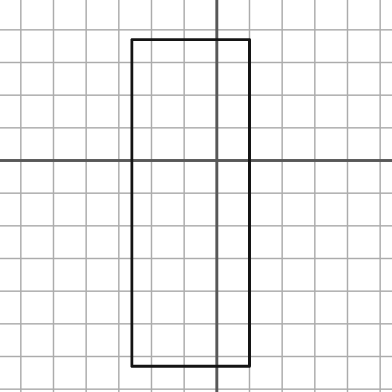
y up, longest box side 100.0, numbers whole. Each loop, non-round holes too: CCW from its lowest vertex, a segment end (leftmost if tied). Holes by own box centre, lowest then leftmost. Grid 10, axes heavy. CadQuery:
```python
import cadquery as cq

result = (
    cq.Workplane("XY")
    .moveTo(-26.0, -63.0)
    .lineTo(10.0, -63.0)
    .lineTo(10.0, 37.0)
    .lineTo(-26.0, 37.0)
    .close()
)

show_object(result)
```